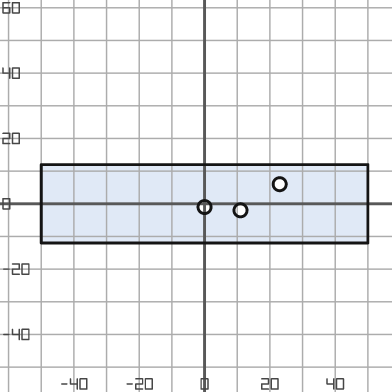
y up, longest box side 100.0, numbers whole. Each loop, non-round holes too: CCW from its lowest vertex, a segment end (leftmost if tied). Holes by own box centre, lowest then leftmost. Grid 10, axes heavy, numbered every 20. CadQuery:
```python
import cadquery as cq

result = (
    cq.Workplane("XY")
    .moveTo(-50.0, -12.0)
    .lineTo(50.0, -12.0)
    .lineTo(50.0, 12.0)
    .lineTo(-50.0, 12.0)
    .close()
    .moveTo(11.0, -2.0)
    .circle(2.0)
    .moveTo(0.0, -1.0)
    .circle(2.0)
    .moveTo(23.0, 6.0)
    .circle(2.0)
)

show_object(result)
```